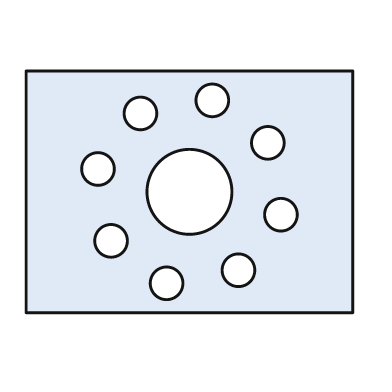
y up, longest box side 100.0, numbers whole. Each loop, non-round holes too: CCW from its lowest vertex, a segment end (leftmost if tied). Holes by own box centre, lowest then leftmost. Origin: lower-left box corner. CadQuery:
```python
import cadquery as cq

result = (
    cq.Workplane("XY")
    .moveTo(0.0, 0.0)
    .lineTo(100.0, 0.0)
    .lineTo(100.0, 74.0)
    .lineTo(0.0, 74.0)
    .close()
    .moveTo(43.0, 9.0)
    .circle(5.0)
    .moveTo(65.0, 13.0)
    .circle(5.0)
    .moveTo(26.0, 22.0)
    .circle(5.0)
    .moveTo(78.0, 30.0)
    .circle(5.0)
    .moveTo(50.0, 37.0)
    .circle(13.0)
    .moveTo(22.0, 44.0)
    .circle(5.0)
    .moveTo(74.0, 52.0)
    .circle(5.0)
    .moveTo(35.0, 61.0)
    .circle(5.0)
    .moveTo(57.0, 65.0)
    .circle(5.0)
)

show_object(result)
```